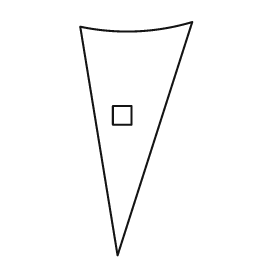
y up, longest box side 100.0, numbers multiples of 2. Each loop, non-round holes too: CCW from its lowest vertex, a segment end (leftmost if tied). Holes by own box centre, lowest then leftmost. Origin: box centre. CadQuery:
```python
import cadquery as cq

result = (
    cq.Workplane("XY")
    .moveTo(-8.0, -50.0)
    .lineTo(24.0, 50.0)
    .threePointArc((0.0, 46.0), (-24.0, 48.0))
    .close()
    .moveTo(-10.0, 6.0)
    .lineTo(-2.0, 6.0)
    .lineTo(-2.0, 14.0)
    .lineTo(-10.0, 14.0)
    .close()
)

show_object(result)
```